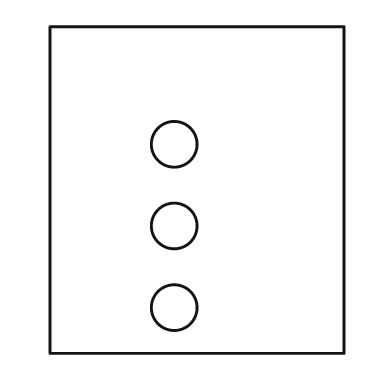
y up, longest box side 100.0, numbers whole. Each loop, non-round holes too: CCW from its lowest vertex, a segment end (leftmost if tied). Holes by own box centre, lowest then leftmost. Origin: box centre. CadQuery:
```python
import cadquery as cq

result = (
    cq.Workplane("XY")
    .moveTo(-45.0, -50.0)
    .lineTo(45.0, -50.0)
    .lineTo(45.0, 50.0)
    .lineTo(-45.0, 50.0)
    .close()
    .moveTo(-7.0, -36.0)
    .circle(7.0)
    .moveTo(-7.0, -11.0)
    .circle(7.0)
    .moveTo(-7.0, 14.0)
    .circle(7.0)
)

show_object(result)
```